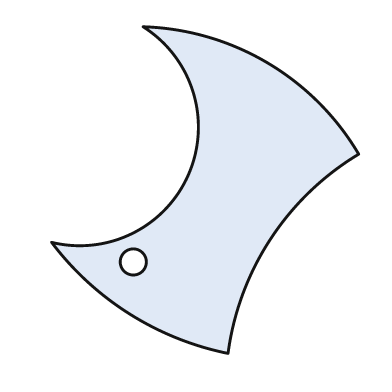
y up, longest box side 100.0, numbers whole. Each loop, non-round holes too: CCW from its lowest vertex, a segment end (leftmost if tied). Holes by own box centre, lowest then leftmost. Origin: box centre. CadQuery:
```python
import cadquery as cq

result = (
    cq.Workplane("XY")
    .moveTo(7.0, -50.0)
    .threePointArc((20.0, -15.0), (47.0, 11.0))
    .threePointArc((19.0, 39.0), (-19.0, 50.0))
    .threePointArc((-5.0, 5.0), (-47.0, -16.0))
    .threePointArc((-23.0, -38.0), (7.0, -50.0))
    .close()
    .moveTo(-22.0, -22.0)
    .circle(4.0)
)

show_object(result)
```